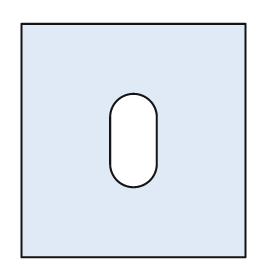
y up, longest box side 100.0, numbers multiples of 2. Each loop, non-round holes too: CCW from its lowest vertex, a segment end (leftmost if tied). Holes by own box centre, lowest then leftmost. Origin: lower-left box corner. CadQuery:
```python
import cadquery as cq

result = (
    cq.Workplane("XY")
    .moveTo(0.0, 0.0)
    .lineTo(96.0, 0.0)
    .lineTo(96.0, 100.0)
    .lineTo(0.0, 100.0)
    .close()
    .moveTo(38.0, 40.0)
    .threePointArc((48.0, 30.0), (58.0, 40.0))
    .lineTo(58.0, 60.0)
    .threePointArc((48.0, 70.0), (38.0, 60.0))
    .close()
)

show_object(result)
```